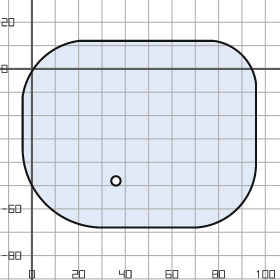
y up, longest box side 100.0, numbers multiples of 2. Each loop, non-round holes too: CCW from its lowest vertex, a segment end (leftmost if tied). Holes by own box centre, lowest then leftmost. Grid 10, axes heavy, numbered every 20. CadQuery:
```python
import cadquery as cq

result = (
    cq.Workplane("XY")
    .moveTo(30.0, -68.0)
    .lineTo(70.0, -68.0)
    .threePointArc((88.0, -60.0), (96.0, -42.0))
    .lineTo(96.0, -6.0)
    .threePointArc((90.0, 6.0), (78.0, 12.0))
    .lineTo(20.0, 12.0)
    .threePointArc((4.0, 4.0), (-4.0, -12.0))
    .lineTo(-4.0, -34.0)
    .threePointArc((6.0, -58.0), (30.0, -68.0))
    .close()
    .moveTo(36.0, -48.0)
    .circle(2.0)
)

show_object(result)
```